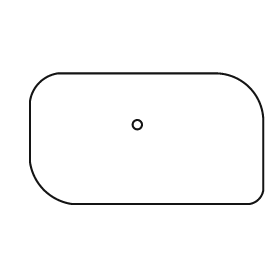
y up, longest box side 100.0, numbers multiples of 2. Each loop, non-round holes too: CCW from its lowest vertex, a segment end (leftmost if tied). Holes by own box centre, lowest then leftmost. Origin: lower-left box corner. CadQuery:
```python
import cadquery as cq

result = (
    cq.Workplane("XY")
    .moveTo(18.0, 0.0)
    .lineTo(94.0, 0.0)
    .threePointArc((98.0, 2.0), (100.0, 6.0))
    .lineTo(100.0, 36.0)
    .threePointArc((94.0, 50.0), (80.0, 56.0))
    .lineTo(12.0, 56.0)
    .threePointArc((4.0, 52.0), (0.0, 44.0))
    .lineTo(0.0, 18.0)
    .threePointArc((6.0, 6.0), (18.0, 0.0))
    .close()
    .moveTo(46.0, 34.0)
    .circle(2.0)
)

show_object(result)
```